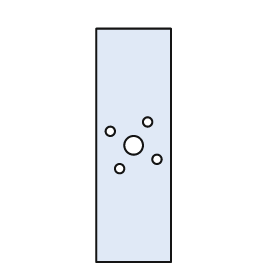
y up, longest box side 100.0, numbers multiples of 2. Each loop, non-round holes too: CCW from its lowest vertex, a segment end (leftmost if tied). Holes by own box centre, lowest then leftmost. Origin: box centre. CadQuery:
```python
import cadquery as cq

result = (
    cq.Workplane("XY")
    .moveTo(-16.0, -50.0)
    .lineTo(16.0, -50.0)
    .lineTo(16.0, 50.0)
    .lineTo(-16.0, 50.0)
    .close()
    .moveTo(-6.0, -10.0)
    .circle(2.0)
    .moveTo(10.0, -6.0)
    .circle(2.0)
    .moveTo(0.0, 0.0)
    .circle(4.0)
    .moveTo(-10.0, 6.0)
    .circle(2.0)
    .moveTo(6.0, 10.0)
    .circle(2.0)
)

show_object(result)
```